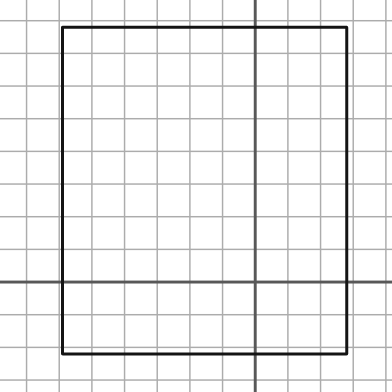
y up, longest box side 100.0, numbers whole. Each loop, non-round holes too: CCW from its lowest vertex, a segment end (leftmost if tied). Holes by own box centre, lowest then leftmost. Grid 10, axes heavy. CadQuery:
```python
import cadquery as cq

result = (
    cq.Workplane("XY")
    .moveTo(-59.0, -22.0)
    .lineTo(28.0, -22.0)
    .lineTo(28.0, 78.0)
    .lineTo(-59.0, 78.0)
    .close()
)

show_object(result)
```